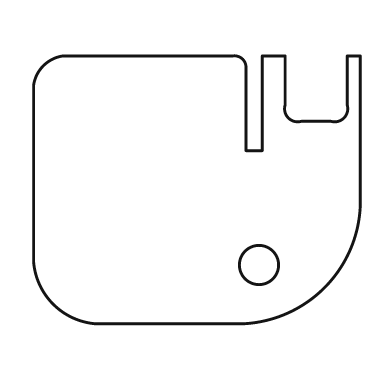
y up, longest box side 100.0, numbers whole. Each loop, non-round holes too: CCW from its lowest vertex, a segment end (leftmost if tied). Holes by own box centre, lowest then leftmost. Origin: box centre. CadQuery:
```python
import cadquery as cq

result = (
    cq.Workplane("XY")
    .moveTo(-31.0, -41.0)
    .lineTo(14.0, -41.0)
    .threePointArc((39.0, -30.0), (50.0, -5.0))
    .lineTo(50.0, 41.0)
    .lineTo(46.0, 41.0)
    .lineTo(46.0, 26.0)
    .threePointArc((45.0, 22.0), (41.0, 21.0))
    .lineTo(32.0, 21.0)
    .threePointArc((28.0, 22.0), (27.0, 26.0))
    .lineTo(27.0, 41.0)
    .lineTo(20.0, 41.0)
    .lineTo(20.0, 12.0)
    .lineTo(15.0, 12.0)
    .lineTo(15.0, 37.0)
    .threePointArc((14.0, 40.0), (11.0, 41.0))
    .lineTo(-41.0, 41.0)
    .threePointArc((-47.0, 38.0), (-50.0, 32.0))
    .lineTo(-50.0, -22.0)
    .threePointArc((-44.0, -35.0), (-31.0, -41.0))
    .close()
    .moveTo(19.0, -23.0)
    .circle(6.0)
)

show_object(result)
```